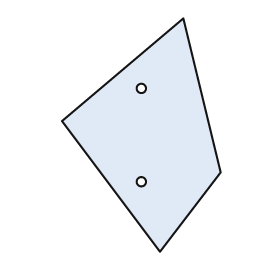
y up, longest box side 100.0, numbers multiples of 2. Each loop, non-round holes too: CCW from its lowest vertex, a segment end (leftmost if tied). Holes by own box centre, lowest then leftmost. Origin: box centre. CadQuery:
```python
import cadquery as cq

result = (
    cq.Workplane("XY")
    .moveTo(8.0, -50.0)
    .lineTo(34.0, -16.0)
    .lineTo(18.0, 50.0)
    .lineTo(-34.0, 6.0)
    .close()
    .moveTo(0.0, -20.0)
    .circle(2.0)
    .moveTo(0.0, 20.0)
    .circle(2.0)
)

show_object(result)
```